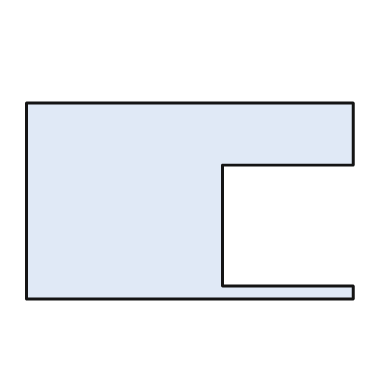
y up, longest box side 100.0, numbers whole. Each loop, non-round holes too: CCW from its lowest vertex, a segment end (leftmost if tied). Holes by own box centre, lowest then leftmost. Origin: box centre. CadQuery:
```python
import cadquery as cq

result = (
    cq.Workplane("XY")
    .moveTo(-50.0, -30.0)
    .lineTo(50.0, -30.0)
    .lineTo(50.0, -26.0)
    .lineTo(10.0, -26.0)
    .lineTo(10.0, 11.0)
    .lineTo(50.0, 11.0)
    .lineTo(50.0, 30.0)
    .lineTo(-50.0, 30.0)
    .close()
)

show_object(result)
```